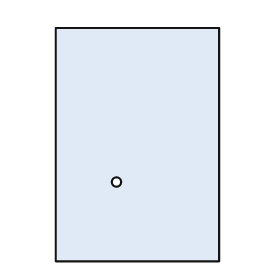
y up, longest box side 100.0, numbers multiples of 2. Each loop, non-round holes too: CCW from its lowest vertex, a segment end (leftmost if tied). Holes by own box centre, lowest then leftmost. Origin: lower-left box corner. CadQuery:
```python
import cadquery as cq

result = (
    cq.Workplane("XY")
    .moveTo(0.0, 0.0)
    .lineTo(70.0, 0.0)
    .lineTo(70.0, 100.0)
    .lineTo(0.0, 100.0)
    .close()
    .moveTo(26.0, 34.0)
    .circle(2.0)
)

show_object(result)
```